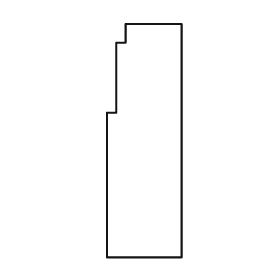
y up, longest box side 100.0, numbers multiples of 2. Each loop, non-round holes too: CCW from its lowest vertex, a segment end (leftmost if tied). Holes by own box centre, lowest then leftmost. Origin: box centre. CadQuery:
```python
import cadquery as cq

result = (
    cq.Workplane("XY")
    .moveTo(-16.0, -50.0)
    .lineTo(16.0, -50.0)
    .lineTo(16.0, 50.0)
    .lineTo(-8.0, 50.0)
    .lineTo(-8.0, 42.0)
    .lineTo(-12.0, 42.0)
    .lineTo(-12.0, 12.0)
    .lineTo(-16.0, 12.0)
    .close()
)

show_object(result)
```